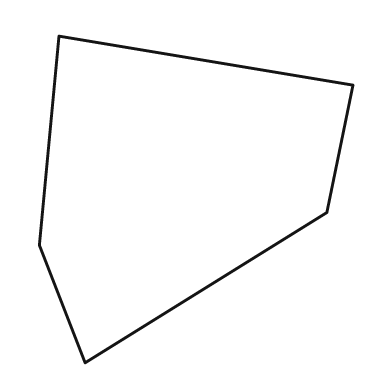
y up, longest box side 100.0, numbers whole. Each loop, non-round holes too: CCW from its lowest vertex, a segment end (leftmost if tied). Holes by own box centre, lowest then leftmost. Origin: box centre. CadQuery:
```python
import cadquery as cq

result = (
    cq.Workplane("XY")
    .moveTo(-34.0, -50.0)
    .lineTo(40.0, -4.0)
    .lineTo(48.0, 35.0)
    .lineTo(-42.0, 50.0)
    .lineTo(-48.0, -14.0)
    .close()
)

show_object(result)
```